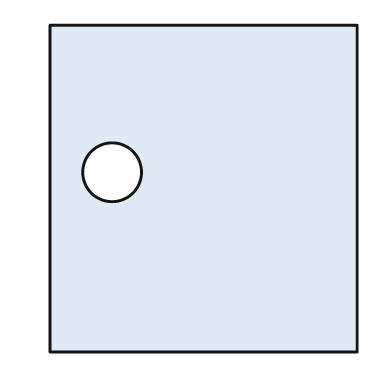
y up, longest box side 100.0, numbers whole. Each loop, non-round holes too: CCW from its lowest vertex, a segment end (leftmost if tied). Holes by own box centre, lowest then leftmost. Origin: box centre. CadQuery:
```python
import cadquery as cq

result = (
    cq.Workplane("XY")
    .moveTo(-47.0, -50.0)
    .lineTo(47.0, -50.0)
    .lineTo(47.0, 50.0)
    .lineTo(-47.0, 50.0)
    .close()
    .moveTo(-28.0, 5.0)
    .circle(9.0)
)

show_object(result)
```